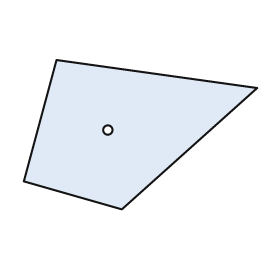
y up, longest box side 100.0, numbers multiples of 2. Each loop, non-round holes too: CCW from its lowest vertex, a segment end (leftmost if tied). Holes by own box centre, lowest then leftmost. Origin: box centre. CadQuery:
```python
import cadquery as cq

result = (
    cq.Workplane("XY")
    .moveTo(-8.0, -32.0)
    .lineTo(50.0, 20.0)
    .lineTo(-36.0, 32.0)
    .lineTo(-50.0, -20.0)
    .close()
    .moveTo(-14.0, 2.0)
    .circle(2.0)
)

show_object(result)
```